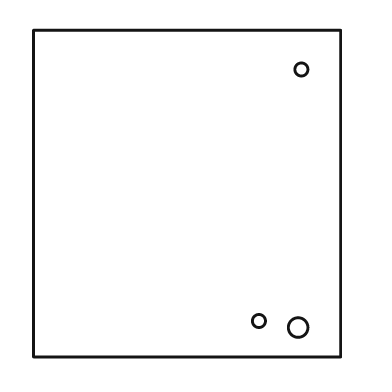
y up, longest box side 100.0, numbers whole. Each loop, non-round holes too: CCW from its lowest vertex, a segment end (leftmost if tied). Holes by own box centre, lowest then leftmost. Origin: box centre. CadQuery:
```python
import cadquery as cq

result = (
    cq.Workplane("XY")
    .moveTo(-47.0, -50.0)
    .lineTo(47.0, -50.0)
    .lineTo(47.0, 50.0)
    .lineTo(-47.0, 50.0)
    .close()
    .moveTo(34.0, -41.0)
    .circle(3.0)
    .moveTo(22.0, -39.0)
    .circle(2.0)
    .moveTo(35.0, 38.0)
    .circle(2.0)
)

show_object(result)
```